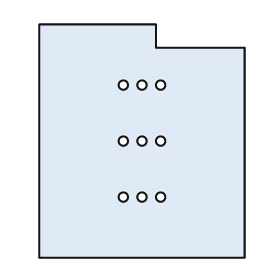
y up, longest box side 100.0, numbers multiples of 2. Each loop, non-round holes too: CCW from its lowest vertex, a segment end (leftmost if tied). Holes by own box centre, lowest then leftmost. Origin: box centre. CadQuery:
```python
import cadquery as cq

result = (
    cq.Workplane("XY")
    .moveTo(-44.0, -50.0)
    .lineTo(44.0, -50.0)
    .lineTo(44.0, 40.0)
    .lineTo(6.0, 40.0)
    .lineTo(6.0, 50.0)
    .lineTo(-44.0, 50.0)
    .close()
    .moveTo(-8.0, -24.0)
    .circle(2.0)
    .moveTo(0.0, -24.0)
    .circle(2.0)
    .moveTo(8.0, -24.0)
    .circle(2.0)
    .moveTo(-8.0, 0.0)
    .circle(2.0)
    .moveTo(0.0, 0.0)
    .circle(2.0)
    .moveTo(8.0, 0.0)
    .circle(2.0)
    .moveTo(-8.0, 24.0)
    .circle(2.0)
    .moveTo(0.0, 24.0)
    .circle(2.0)
    .moveTo(8.0, 24.0)
    .circle(2.0)
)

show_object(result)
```